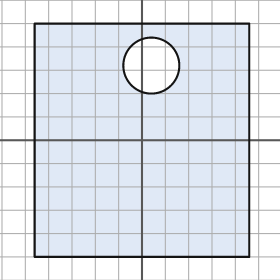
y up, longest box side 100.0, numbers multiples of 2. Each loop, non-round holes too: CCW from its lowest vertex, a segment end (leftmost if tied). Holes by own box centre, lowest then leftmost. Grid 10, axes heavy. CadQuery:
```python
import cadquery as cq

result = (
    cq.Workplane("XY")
    .moveTo(-46.0, -50.0)
    .lineTo(46.0, -50.0)
    .lineTo(46.0, 50.0)
    .lineTo(-46.0, 50.0)
    .close()
    .moveTo(4.0, 32.0)
    .circle(12.0)
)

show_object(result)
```